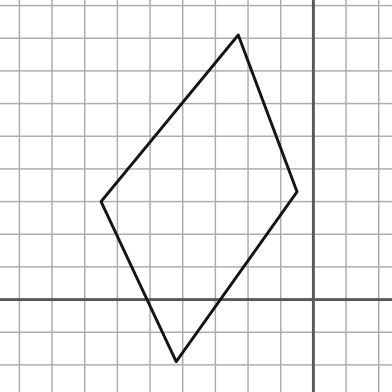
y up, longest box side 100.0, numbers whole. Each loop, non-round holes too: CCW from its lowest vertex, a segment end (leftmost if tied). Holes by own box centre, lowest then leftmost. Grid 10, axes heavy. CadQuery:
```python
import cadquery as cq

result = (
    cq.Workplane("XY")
    .moveTo(-42.0, -19.0)
    .lineTo(-5.0, 33.0)
    .lineTo(-23.0, 81.0)
    .lineTo(-65.0, 30.0)
    .close()
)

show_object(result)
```